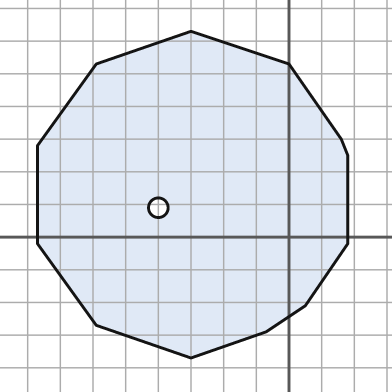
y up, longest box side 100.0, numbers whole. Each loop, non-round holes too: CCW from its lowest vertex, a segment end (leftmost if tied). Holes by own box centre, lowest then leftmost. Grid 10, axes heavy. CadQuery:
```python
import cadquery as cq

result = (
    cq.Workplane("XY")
    .moveTo(-30.0, -37.0)
    .lineTo(-7.0, -29.0)
    .lineTo(5.0, -21.0)
    .lineTo(18.0, -2.0)
    .lineTo(18.0, 25.0)
    .lineTo(16.0, 30.0)
    .lineTo(0.0, 53.0)
    .lineTo(-30.0, 63.0)
    .lineTo(-59.0, 53.0)
    .lineTo(-77.0, 28.0)
    .lineTo(-77.0, -2.0)
    .lineTo(-59.0, -27.0)
    .close()
    .moveTo(-40.0, 9.0)
    .circle(3.0)
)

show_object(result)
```